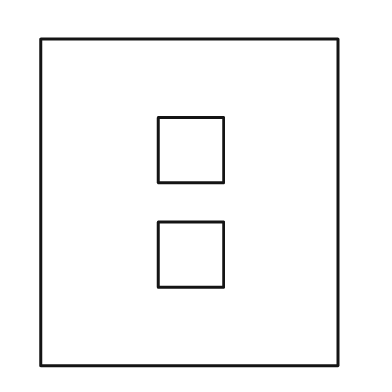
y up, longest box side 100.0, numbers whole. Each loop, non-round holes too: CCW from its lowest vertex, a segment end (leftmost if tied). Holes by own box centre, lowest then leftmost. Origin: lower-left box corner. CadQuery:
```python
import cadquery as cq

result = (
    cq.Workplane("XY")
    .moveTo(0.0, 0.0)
    .lineTo(91.0, 0.0)
    .lineTo(91.0, 100.0)
    .lineTo(0.0, 100.0)
    .close()
    .moveTo(36.0, 24.0)
    .lineTo(56.0, 24.0)
    .lineTo(56.0, 44.0)
    .lineTo(36.0, 44.0)
    .close()
    .moveTo(36.0, 56.0)
    .lineTo(56.0, 56.0)
    .lineTo(56.0, 76.0)
    .lineTo(36.0, 76.0)
    .close()
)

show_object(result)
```